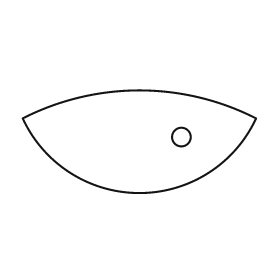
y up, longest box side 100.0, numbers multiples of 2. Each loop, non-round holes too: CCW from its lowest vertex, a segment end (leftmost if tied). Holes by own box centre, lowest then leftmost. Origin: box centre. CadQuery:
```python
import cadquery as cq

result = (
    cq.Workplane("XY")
    .moveTo(-50.0, 10.0)
    .threePointArc((0.0, -22.0), (50.0, 10.0))
    .threePointArc((0.0, 22.0), (-50.0, 10.0))
    .close()
    .moveTo(18.0, 2.0)
    .circle(4.0)
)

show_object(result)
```